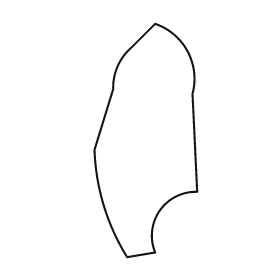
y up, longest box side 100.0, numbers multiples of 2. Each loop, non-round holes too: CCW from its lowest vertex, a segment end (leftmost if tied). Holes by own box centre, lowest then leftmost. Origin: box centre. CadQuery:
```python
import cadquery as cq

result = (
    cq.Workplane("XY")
    .moveTo(-8.0, -50.0)
    .lineTo(4.0, -48.0)
    .threePointArc((6.0, -30.0), (22.0, -22.0))
    .lineTo(20.0, 20.0)
    .threePointArc((18.0, 38.0), (4.0, 50.0))
    .lineTo(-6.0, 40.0)
    .threePointArc((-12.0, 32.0), (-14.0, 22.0))
    .lineTo(-22.0, -4.0)
    .threePointArc((-18.0, -28.0), (-8.0, -50.0))
    .close()
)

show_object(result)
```